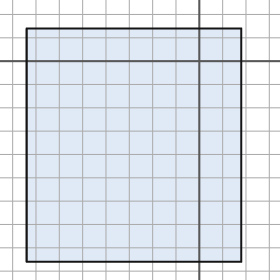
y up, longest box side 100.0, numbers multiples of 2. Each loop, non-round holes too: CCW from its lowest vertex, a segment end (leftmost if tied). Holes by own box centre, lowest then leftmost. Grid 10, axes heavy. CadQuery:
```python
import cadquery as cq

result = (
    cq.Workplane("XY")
    .moveTo(-74.0, -86.0)
    .lineTo(18.0, -86.0)
    .lineTo(18.0, 14.0)
    .lineTo(-74.0, 14.0)
    .close()
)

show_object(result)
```